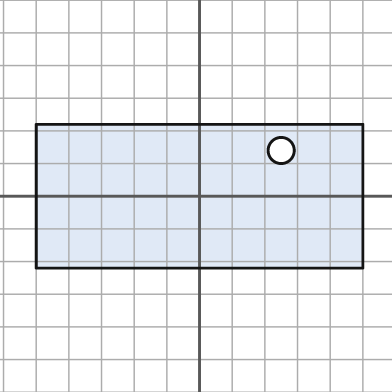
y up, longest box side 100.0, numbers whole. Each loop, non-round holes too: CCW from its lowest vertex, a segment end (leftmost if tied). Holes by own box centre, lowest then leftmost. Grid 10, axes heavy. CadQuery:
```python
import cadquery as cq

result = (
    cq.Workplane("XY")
    .moveTo(-50.0, -22.0)
    .lineTo(50.0, -22.0)
    .lineTo(50.0, 22.0)
    .lineTo(-50.0, 22.0)
    .close()
    .moveTo(25.0, 14.0)
    .circle(4.0)
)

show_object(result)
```